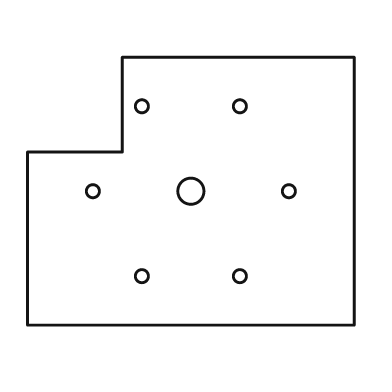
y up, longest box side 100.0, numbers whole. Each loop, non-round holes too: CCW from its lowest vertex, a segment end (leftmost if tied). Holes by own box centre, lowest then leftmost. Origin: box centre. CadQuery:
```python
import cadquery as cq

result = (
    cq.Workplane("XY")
    .moveTo(-50.0, -41.0)
    .lineTo(50.0, -41.0)
    .lineTo(50.0, 41.0)
    .lineTo(-21.0, 41.0)
    .lineTo(-21.0, 12.0)
    .lineTo(-50.0, 12.0)
    .close()
    .moveTo(-15.0, -26.0)
    .circle(2.0)
    .moveTo(15.0, -26.0)
    .circle(2.0)
    .moveTo(-30.0, 0.0)
    .circle(2.0)
    .moveTo(0.0, 0.0)
    .circle(4.0)
    .moveTo(30.0, 0.0)
    .circle(2.0)
    .moveTo(-15.0, 26.0)
    .circle(2.0)
    .moveTo(15.0, 26.0)
    .circle(2.0)
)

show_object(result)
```